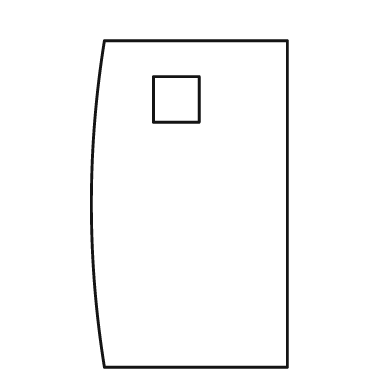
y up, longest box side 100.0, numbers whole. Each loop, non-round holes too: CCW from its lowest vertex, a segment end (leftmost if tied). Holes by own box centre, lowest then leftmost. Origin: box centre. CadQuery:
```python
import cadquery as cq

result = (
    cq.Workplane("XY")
    .moveTo(-26.0, -50.0)
    .lineTo(30.0, -50.0)
    .lineTo(30.0, 50.0)
    .lineTo(-26.0, 50.0)
    .threePointArc((-30.0, 0.0), (-26.0, -50.0))
    .close()
    .moveTo(-11.0, 25.0)
    .lineTo(3.0, 25.0)
    .lineTo(3.0, 39.0)
    .lineTo(-11.0, 39.0)
    .close()
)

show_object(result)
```